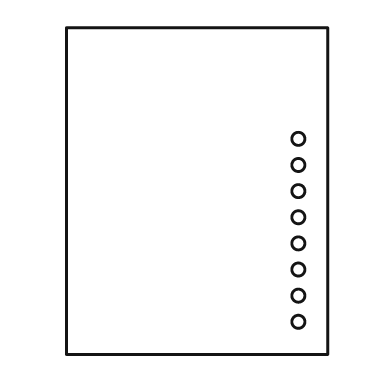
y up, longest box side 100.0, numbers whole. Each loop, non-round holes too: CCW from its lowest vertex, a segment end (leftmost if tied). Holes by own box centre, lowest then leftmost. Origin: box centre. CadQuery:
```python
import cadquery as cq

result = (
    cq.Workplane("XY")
    .moveTo(-40.0, -50.0)
    .lineTo(40.0, -50.0)
    .lineTo(40.0, 50.0)
    .lineTo(-40.0, 50.0)
    .close()
    .moveTo(31.0, -40.0)
    .circle(2.0)
    .moveTo(31.0, -32.0)
    .circle(2.0)
    .moveTo(31.0, -24.0)
    .circle(2.0)
    .moveTo(31.0, -16.0)
    .circle(2.0)
    .moveTo(31.0, -8.0)
    .circle(2.0)
    .moveTo(31.0, 0.0)
    .circle(2.0)
    .moveTo(31.0, 8.0)
    .circle(2.0)
    .moveTo(31.0, 16.0)
    .circle(2.0)
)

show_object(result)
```